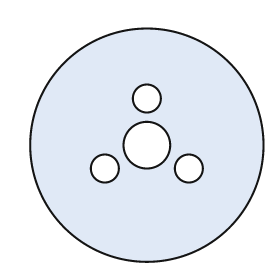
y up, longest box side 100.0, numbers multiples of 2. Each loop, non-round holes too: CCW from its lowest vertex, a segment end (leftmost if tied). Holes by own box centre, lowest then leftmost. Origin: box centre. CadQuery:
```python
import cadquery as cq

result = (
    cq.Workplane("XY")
    .moveTo(0.0, 0.0)
    .circle(50.0)
    .moveTo(-18.0, -10.0)
    .circle(6.0)
    .moveTo(18.0, -10.0)
    .circle(6.0)
    .moveTo(0.0, 0.0)
    .circle(10.0)
    .moveTo(0.0, 20.0)
    .circle(6.0)
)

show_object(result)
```